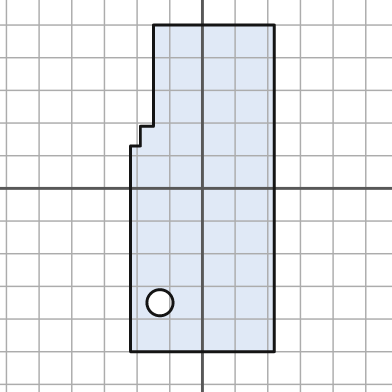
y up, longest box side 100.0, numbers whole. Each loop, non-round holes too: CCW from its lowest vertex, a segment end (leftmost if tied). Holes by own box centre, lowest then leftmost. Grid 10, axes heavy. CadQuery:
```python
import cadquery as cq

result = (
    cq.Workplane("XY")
    .moveTo(-22.0, -50.0)
    .lineTo(22.0, -50.0)
    .lineTo(22.0, 50.0)
    .lineTo(-15.0, 50.0)
    .lineTo(-15.0, 19.0)
    .lineTo(-19.0, 19.0)
    .lineTo(-19.0, 13.0)
    .lineTo(-22.0, 13.0)
    .close()
    .moveTo(-13.0, -35.0)
    .circle(4.0)
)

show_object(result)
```